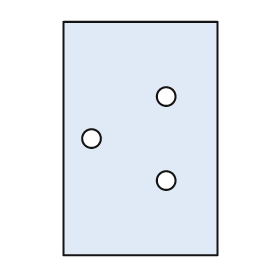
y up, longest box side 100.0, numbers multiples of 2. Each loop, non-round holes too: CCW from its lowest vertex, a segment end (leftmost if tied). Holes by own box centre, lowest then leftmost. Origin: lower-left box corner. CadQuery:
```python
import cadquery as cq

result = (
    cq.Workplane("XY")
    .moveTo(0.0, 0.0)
    .lineTo(66.0, 0.0)
    .lineTo(66.0, 100.0)
    .lineTo(0.0, 100.0)
    .close()
    .moveTo(44.0, 32.0)
    .circle(4.0)
    .moveTo(12.0, 50.0)
    .circle(4.0)
    .moveTo(44.0, 68.0)
    .circle(4.0)
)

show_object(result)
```